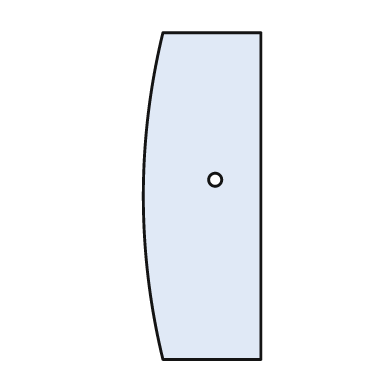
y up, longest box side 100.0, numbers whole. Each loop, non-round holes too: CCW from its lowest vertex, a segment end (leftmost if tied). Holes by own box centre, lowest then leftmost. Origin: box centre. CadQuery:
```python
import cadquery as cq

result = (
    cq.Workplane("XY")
    .moveTo(-12.0, -50.0)
    .lineTo(18.0, -50.0)
    .lineTo(18.0, 50.0)
    .lineTo(-12.0, 50.0)
    .threePointArc((-18.0, 0.0), (-12.0, -50.0))
    .close()
    .moveTo(4.0, 5.0)
    .circle(2.0)
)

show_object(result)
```